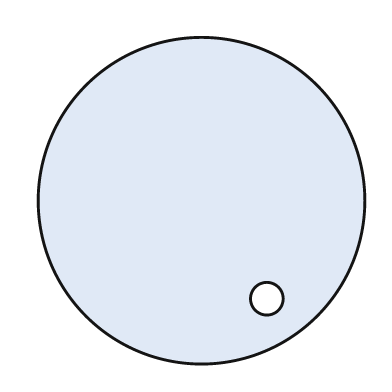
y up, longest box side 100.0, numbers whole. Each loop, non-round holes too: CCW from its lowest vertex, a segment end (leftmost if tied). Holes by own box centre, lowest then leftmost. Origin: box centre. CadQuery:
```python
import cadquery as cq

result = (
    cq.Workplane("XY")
    .moveTo(0.0, 0.0)
    .circle(50.0)
    .moveTo(20.0, -30.0)
    .circle(5.0)
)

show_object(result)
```